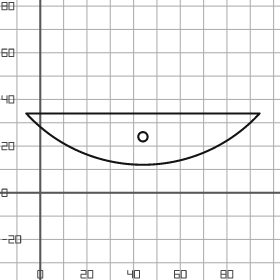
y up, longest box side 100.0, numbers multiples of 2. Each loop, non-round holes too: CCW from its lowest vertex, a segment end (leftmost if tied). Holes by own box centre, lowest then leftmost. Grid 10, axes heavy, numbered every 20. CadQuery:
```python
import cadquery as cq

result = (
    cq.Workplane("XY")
    .moveTo(-6.0, 34.0)
    .threePointArc((44.0, 12.0), (94.0, 34.0))
    .close()
    .moveTo(44.0, 24.0)
    .circle(2.0)
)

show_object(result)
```